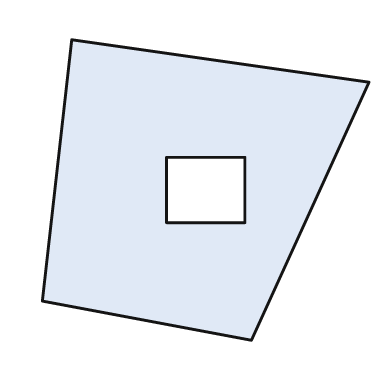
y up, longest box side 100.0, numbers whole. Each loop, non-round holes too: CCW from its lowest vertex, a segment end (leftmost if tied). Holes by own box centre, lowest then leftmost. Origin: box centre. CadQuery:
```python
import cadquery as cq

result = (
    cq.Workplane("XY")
    .moveTo(14.0, -46.0)
    .lineTo(50.0, 33.0)
    .lineTo(-41.0, 46.0)
    .lineTo(-50.0, -34.0)
    .close()
    .moveTo(-12.0, -10.0)
    .lineTo(12.0, -10.0)
    .lineTo(12.0, 10.0)
    .lineTo(-12.0, 10.0)
    .close()
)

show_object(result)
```